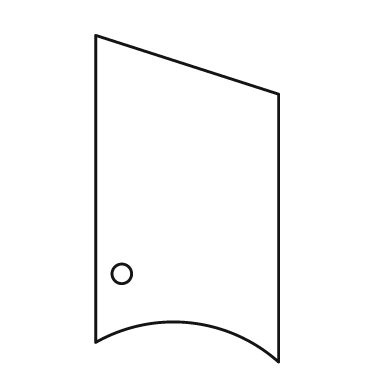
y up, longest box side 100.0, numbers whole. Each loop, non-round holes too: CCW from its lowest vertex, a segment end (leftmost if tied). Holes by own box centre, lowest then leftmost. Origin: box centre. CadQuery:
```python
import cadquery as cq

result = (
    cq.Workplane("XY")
    .moveTo(28.0, -50.0)
    .lineTo(28.0, 32.0)
    .lineTo(-28.0, 50.0)
    .lineTo(-28.0, -44.0)
    .threePointArc((1.0, -38.0), (28.0, -50.0))
    .close()
    .moveTo(-20.0, -23.0)
    .circle(3.0)
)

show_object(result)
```